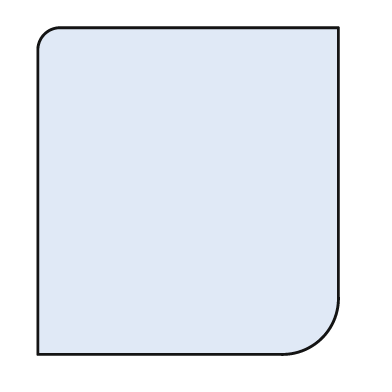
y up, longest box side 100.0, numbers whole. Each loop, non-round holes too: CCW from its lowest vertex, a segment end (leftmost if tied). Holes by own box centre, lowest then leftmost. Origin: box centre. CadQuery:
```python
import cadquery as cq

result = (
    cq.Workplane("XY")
    .moveTo(-46.0, -50.0)
    .lineTo(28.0, -50.0)
    .threePointArc((41.0, -45.0), (46.0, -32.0))
    .lineTo(46.0, 50.0)
    .lineTo(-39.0, 50.0)
    .threePointArc((-44.0, 48.0), (-46.0, 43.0))
    .close()
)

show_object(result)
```